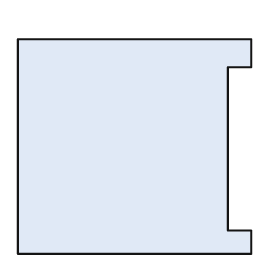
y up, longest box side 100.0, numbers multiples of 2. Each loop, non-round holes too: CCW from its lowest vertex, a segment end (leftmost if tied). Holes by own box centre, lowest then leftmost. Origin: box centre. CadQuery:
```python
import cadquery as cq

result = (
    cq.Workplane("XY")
    .moveTo(-50.0, -46.0)
    .lineTo(50.0, -46.0)
    .lineTo(50.0, -36.0)
    .lineTo(40.0, -36.0)
    .lineTo(40.0, 34.0)
    .lineTo(50.0, 34.0)
    .lineTo(50.0, 46.0)
    .lineTo(-50.0, 46.0)
    .close()
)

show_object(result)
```